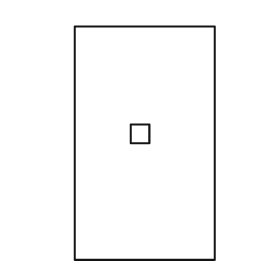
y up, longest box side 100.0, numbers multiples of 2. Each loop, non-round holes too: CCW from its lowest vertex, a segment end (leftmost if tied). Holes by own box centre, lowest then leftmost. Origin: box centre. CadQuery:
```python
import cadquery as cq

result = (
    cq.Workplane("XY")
    .moveTo(-30.0, -50.0)
    .lineTo(30.0, -50.0)
    .lineTo(30.0, 50.0)
    .lineTo(-30.0, 50.0)
    .close()
    .moveTo(-6.0, 0.0)
    .lineTo(2.0, 0.0)
    .lineTo(2.0, 8.0)
    .lineTo(-6.0, 8.0)
    .close()
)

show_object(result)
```